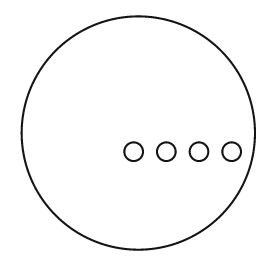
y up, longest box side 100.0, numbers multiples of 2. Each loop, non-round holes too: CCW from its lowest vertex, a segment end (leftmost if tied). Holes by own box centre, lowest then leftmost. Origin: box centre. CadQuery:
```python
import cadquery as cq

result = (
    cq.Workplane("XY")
    .moveTo(0.0, 0.0)
    .circle(50.0)
    .moveTo(-2.0, -8.0)
    .circle(4.0)
    .moveTo(12.0, -8.0)
    .circle(4.0)
    .moveTo(26.0, -8.0)
    .circle(4.0)
    .moveTo(40.0, -8.0)
    .circle(4.0)
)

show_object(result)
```